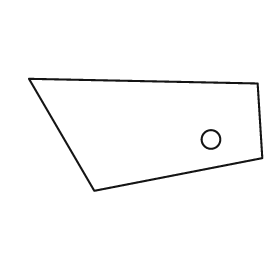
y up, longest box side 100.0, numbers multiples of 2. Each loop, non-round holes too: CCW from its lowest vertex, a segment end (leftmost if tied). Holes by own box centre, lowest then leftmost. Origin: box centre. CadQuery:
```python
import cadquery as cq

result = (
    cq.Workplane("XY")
    .moveTo(-22.0, -24.0)
    .lineTo(50.0, -10.0)
    .lineTo(48.0, 22.0)
    .lineTo(-50.0, 24.0)
    .close()
    .moveTo(28.0, -2.0)
    .circle(4.0)
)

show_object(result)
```